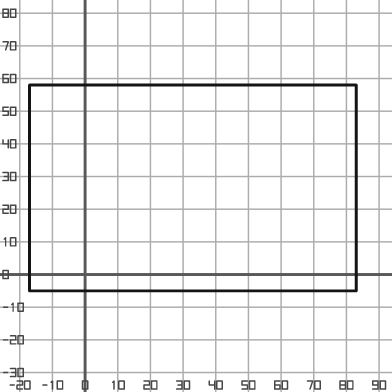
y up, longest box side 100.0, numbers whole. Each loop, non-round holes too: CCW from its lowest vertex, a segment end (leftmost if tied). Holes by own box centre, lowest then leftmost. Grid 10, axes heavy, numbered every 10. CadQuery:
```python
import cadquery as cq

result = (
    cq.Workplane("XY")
    .moveTo(-17.0, -5.0)
    .lineTo(83.0, -5.0)
    .lineTo(83.0, 58.0)
    .lineTo(-17.0, 58.0)
    .close()
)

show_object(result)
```